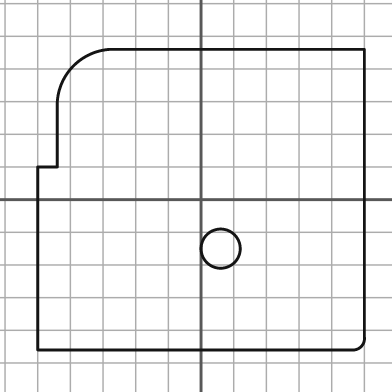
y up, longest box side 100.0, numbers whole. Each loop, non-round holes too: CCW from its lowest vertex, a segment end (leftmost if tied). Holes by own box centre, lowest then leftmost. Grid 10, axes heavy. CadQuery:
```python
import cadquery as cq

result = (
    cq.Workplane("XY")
    .moveTo(-50.0, -46.0)
    .lineTo(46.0, -46.0)
    .threePointArc((49.0, -45.0), (50.0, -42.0))
    .lineTo(50.0, 46.0)
    .lineTo(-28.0, 46.0)
    .threePointArc((-39.0, 41.0), (-44.0, 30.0))
    .lineTo(-44.0, 10.0)
    .lineTo(-50.0, 10.0)
    .close()
    .moveTo(6.0, -15.0)
    .circle(6.0)
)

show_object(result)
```